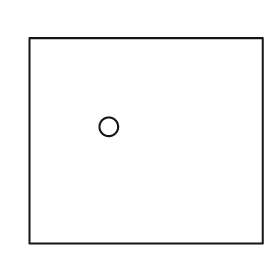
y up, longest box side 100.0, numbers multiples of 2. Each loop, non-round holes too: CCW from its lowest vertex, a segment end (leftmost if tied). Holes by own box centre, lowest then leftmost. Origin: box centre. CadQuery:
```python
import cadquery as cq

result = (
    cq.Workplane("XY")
    .moveTo(-50.0, -44.0)
    .lineTo(50.0, -44.0)
    .lineTo(50.0, 44.0)
    .lineTo(-50.0, 44.0)
    .close()
    .moveTo(-16.0, 6.0)
    .circle(4.0)
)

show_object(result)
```